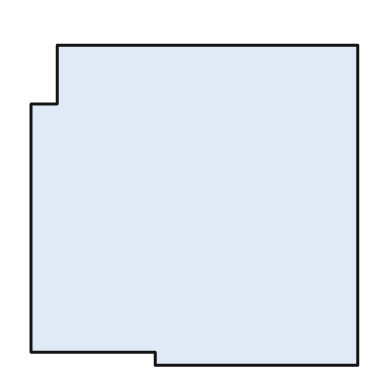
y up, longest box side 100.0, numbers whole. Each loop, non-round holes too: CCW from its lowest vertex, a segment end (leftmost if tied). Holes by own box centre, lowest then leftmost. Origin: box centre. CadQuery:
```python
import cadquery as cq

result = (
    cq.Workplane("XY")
    .moveTo(-12.0, -49.0)
    .lineTo(50.0, -49.0)
    .lineTo(50.0, 49.0)
    .lineTo(-42.0, 49.0)
    .lineTo(-42.0, 31.0)
    .lineTo(-50.0, 31.0)
    .lineTo(-50.0, -45.0)
    .lineTo(-12.0, -45.0)
    .close()
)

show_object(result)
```